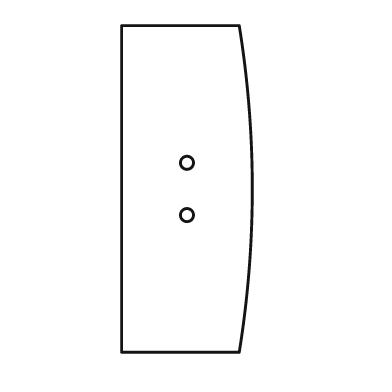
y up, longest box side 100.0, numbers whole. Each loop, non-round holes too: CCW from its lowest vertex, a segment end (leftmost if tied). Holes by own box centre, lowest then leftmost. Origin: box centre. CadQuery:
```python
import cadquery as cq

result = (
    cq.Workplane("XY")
    .moveTo(-20.0, -50.0)
    .lineTo(16.0, -50.0)
    .threePointArc((20.0, 0.0), (16.0, 50.0))
    .lineTo(-20.0, 50.0)
    .close()
    .moveTo(0.0, -8.0)
    .circle(2.0)
    .moveTo(0.0, 8.0)
    .circle(2.0)
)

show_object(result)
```